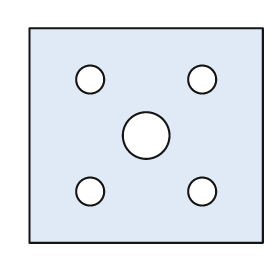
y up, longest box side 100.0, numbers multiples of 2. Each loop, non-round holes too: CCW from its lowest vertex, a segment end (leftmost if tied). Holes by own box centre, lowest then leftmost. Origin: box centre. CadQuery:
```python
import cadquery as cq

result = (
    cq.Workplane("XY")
    .moveTo(-50.0, -46.0)
    .lineTo(50.0, -46.0)
    .lineTo(50.0, 46.0)
    .lineTo(-50.0, 46.0)
    .close()
    .moveTo(-24.0, -24.0)
    .circle(6.0)
    .moveTo(24.0, -24.0)
    .circle(6.0)
    .moveTo(0.0, 0.0)
    .circle(10.0)
    .moveTo(-24.0, 24.0)
    .circle(6.0)
    .moveTo(24.0, 24.0)
    .circle(6.0)
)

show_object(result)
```